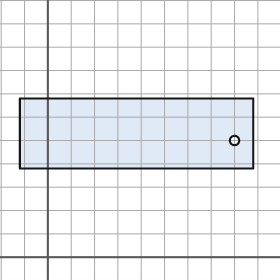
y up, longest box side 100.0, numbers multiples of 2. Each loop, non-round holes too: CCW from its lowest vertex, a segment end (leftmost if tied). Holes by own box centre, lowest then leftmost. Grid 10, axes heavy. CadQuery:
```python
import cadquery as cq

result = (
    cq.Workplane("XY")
    .moveTo(-12.0, 38.0)
    .lineTo(88.0, 38.0)
    .lineTo(88.0, 68.0)
    .lineTo(-12.0, 68.0)
    .close()
    .moveTo(80.0, 50.0)
    .circle(2.0)
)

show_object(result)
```